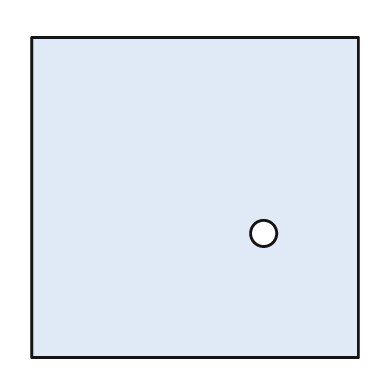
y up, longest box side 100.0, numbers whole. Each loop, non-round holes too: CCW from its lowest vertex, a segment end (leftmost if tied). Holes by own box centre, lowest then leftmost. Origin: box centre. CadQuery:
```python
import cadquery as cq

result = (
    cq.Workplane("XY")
    .moveTo(-50.0, -49.0)
    .lineTo(50.0, -49.0)
    .lineTo(50.0, 49.0)
    .lineTo(-50.0, 49.0)
    .close()
    .moveTo(21.0, -11.0)
    .circle(4.0)
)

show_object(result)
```